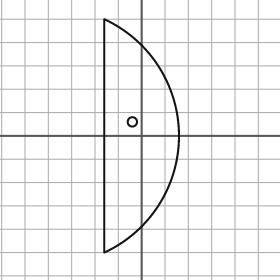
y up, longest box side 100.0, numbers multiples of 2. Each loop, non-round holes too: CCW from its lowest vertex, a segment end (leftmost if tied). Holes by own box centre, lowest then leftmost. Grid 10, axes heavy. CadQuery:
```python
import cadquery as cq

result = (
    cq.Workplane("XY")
    .moveTo(-16.0, -50.0)
    .threePointArc((16.0, 0.0), (-16.0, 50.0))
    .close()
    .moveTo(-4.0, 6.0)
    .circle(2.0)
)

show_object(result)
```